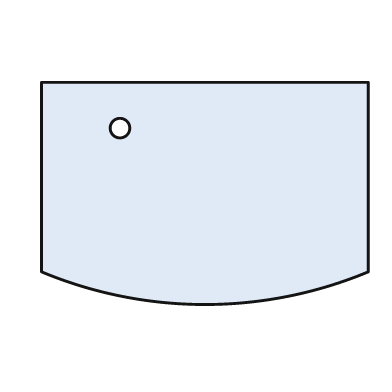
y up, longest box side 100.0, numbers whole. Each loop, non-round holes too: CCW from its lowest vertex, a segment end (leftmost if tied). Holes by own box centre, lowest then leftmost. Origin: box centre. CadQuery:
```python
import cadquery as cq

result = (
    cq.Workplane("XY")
    .moveTo(-50.0, -24.0)
    .threePointArc((0.0, -34.0), (50.0, -24.0))
    .lineTo(50.0, 34.0)
    .lineTo(-50.0, 34.0)
    .close()
    .moveTo(-26.0, 20.0)
    .circle(3.0)
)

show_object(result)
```